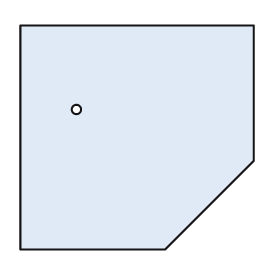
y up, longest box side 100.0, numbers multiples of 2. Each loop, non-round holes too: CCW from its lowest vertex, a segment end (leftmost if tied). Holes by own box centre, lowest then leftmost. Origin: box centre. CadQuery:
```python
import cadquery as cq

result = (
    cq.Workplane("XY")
    .moveTo(-50.0, -48.0)
    .lineTo(12.0, -48.0)
    .lineTo(50.0, -10.0)
    .lineTo(50.0, 48.0)
    .lineTo(-50.0, 48.0)
    .close()
    .moveTo(-26.0, 12.0)
    .circle(2.0)
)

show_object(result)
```